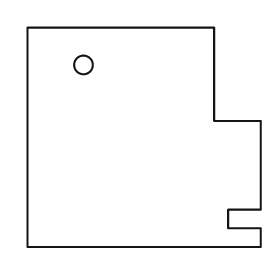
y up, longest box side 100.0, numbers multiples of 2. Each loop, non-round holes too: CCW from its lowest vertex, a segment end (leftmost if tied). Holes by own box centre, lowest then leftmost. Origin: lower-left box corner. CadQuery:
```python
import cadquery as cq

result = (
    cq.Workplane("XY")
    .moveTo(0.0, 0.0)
    .lineTo(100.0, 0.0)
    .lineTo(100.0, 8.0)
    .lineTo(86.0, 8.0)
    .lineTo(86.0, 16.0)
    .lineTo(100.0, 16.0)
    .lineTo(100.0, 54.0)
    .lineTo(80.0, 54.0)
    .lineTo(80.0, 94.0)
    .lineTo(0.0, 94.0)
    .close()
    .moveTo(24.0, 78.0)
    .circle(4.0)
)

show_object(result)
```